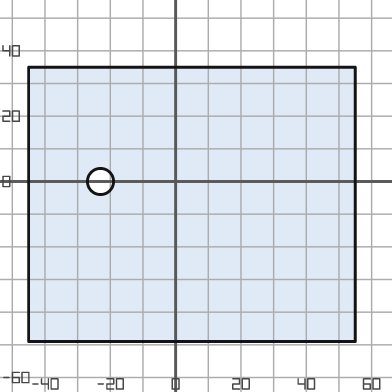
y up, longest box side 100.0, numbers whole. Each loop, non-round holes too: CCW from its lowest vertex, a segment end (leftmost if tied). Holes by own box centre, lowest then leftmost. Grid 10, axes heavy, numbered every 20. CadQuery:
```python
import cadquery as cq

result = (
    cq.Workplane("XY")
    .moveTo(-45.0, -49.0)
    .lineTo(55.0, -49.0)
    .lineTo(55.0, 35.0)
    .lineTo(-45.0, 35.0)
    .close()
    .moveTo(-23.0, 0.0)
    .circle(4.0)
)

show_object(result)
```